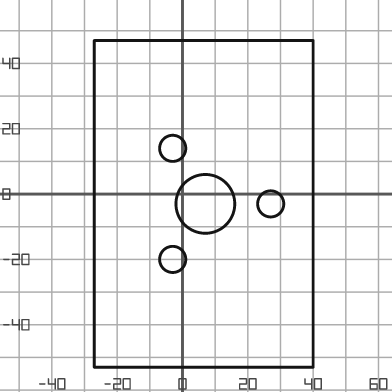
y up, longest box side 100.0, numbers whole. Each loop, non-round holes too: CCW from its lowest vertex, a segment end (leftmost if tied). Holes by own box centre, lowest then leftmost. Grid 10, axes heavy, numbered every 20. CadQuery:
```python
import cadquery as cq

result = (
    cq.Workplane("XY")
    .moveTo(-27.0, -53.0)
    .lineTo(40.0, -53.0)
    .lineTo(40.0, 47.0)
    .lineTo(-27.0, 47.0)
    .close()
    .moveTo(-3.0, -20.0)
    .circle(4.0)
    .moveTo(7.0, -3.0)
    .circle(9.0)
    .moveTo(27.0, -3.0)
    .circle(4.0)
    .moveTo(-3.0, 14.0)
    .circle(4.0)
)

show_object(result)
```